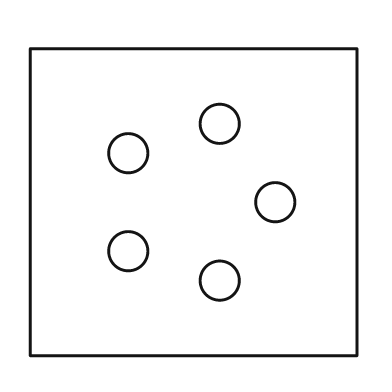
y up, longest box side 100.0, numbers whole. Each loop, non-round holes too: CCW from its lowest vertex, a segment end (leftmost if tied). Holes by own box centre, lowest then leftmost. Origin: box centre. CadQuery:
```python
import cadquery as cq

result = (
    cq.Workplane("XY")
    .moveTo(-50.0, -47.0)
    .lineTo(50.0, -47.0)
    .lineTo(50.0, 47.0)
    .lineTo(-50.0, 47.0)
    .close()
    .moveTo(8.0, -24.0)
    .circle(6.0)
    .moveTo(-20.0, -15.0)
    .circle(6.0)
    .moveTo(25.0, 0.0)
    .circle(6.0)
    .moveTo(-20.0, 15.0)
    .circle(6.0)
    .moveTo(8.0, 24.0)
    .circle(6.0)
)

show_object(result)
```